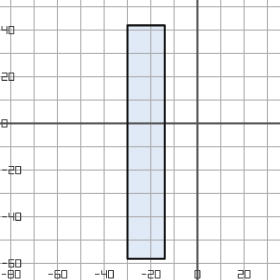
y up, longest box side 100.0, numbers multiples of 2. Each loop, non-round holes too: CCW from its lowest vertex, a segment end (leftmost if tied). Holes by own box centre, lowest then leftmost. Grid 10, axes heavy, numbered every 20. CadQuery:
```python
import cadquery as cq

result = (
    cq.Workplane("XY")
    .moveTo(-30.0, -58.0)
    .lineTo(-14.0, -58.0)
    .lineTo(-14.0, 42.0)
    .lineTo(-30.0, 42.0)
    .close()
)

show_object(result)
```